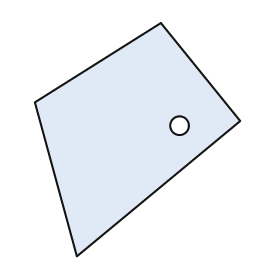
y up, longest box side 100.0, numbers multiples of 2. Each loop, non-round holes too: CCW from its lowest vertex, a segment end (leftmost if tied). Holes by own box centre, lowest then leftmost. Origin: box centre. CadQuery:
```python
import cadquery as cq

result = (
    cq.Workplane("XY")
    .moveTo(-26.0, -50.0)
    .lineTo(44.0, 8.0)
    .lineTo(10.0, 50.0)
    .lineTo(-44.0, 16.0)
    .close()
    .moveTo(18.0, 6.0)
    .circle(4.0)
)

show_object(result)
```